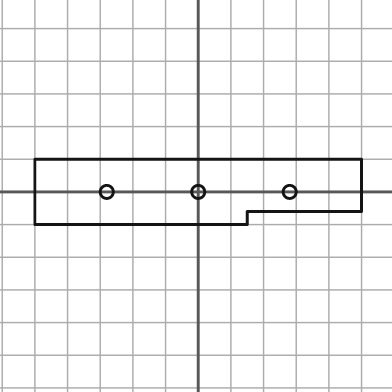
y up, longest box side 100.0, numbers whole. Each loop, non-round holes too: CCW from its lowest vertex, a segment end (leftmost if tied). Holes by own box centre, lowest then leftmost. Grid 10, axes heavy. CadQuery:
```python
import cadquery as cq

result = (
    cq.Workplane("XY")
    .moveTo(-50.0, -10.0)
    .lineTo(15.0, -10.0)
    .lineTo(15.0, -6.0)
    .lineTo(50.0, -6.0)
    .lineTo(50.0, 10.0)
    .lineTo(-50.0, 10.0)
    .close()
    .moveTo(-28.0, 0.0)
    .circle(2.0)
    .moveTo(0.0, 0.0)
    .circle(2.0)
    .moveTo(28.0, 0.0)
    .circle(2.0)
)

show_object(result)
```